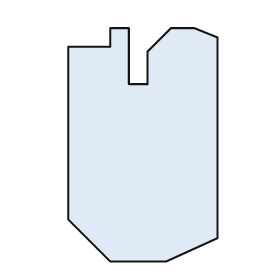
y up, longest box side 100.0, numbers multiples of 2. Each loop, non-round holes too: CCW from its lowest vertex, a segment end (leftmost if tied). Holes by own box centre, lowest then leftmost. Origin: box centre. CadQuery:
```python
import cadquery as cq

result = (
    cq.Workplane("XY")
    .moveTo(-14.0, -50.0)
    .lineTo(10.0, -50.0)
    .lineTo(32.0, -40.0)
    .lineTo(32.0, 46.0)
    .lineTo(22.0, 50.0)
    .lineTo(12.0, 50.0)
    .lineTo(2.0, 40.0)
    .lineTo(2.0, 26.0)
    .lineTo(-6.0, 26.0)
    .lineTo(-6.0, 50.0)
    .lineTo(-14.0, 50.0)
    .lineTo(-14.0, 42.0)
    .lineTo(-32.0, 42.0)
    .lineTo(-32.0, -32.0)
    .close()
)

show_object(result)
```